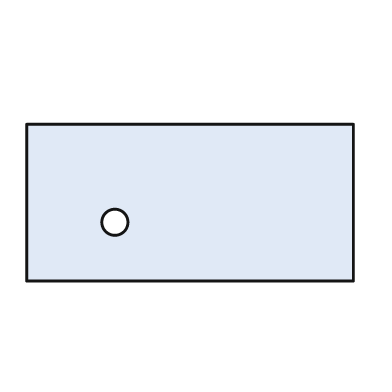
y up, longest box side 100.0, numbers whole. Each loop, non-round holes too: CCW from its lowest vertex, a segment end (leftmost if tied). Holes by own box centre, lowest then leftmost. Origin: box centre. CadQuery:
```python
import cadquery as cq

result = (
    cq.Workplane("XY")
    .moveTo(-50.0, -24.0)
    .lineTo(50.0, -24.0)
    .lineTo(50.0, 24.0)
    .lineTo(-50.0, 24.0)
    .close()
    .moveTo(-23.0, -6.0)
    .circle(4.0)
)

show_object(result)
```